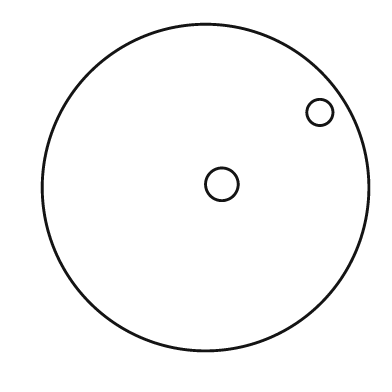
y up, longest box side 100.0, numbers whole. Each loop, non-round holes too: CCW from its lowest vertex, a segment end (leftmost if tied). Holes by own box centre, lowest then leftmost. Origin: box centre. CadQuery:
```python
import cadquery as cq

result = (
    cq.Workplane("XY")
    .moveTo(0.0, 0.0)
    .circle(50.0)
    .moveTo(5.0, 1.0)
    .circle(5.0)
    .moveTo(35.0, 23.0)
    .circle(4.0)
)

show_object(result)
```